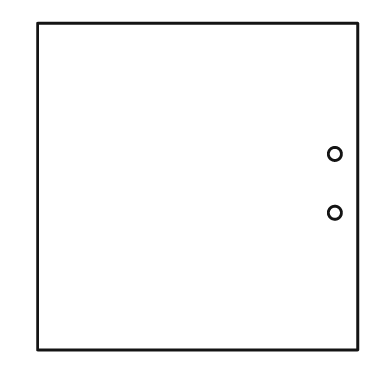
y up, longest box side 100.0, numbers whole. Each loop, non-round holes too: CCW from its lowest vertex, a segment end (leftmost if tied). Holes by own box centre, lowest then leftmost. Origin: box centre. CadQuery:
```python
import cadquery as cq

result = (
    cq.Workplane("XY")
    .moveTo(-49.0, -50.0)
    .lineTo(49.0, -50.0)
    .lineTo(49.0, 50.0)
    .lineTo(-49.0, 50.0)
    .close()
    .moveTo(42.0, -8.0)
    .circle(2.0)
    .moveTo(42.0, 10.0)
    .circle(2.0)
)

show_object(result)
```